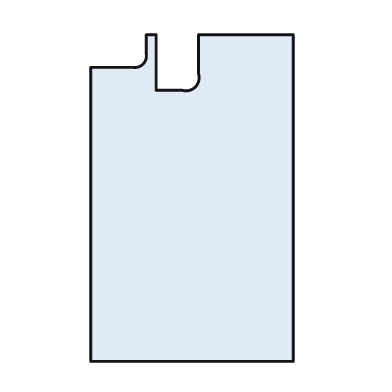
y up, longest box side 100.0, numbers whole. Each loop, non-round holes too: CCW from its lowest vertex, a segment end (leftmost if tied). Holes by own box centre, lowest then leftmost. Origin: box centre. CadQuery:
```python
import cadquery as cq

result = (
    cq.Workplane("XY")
    .moveTo(-31.0, -50.0)
    .lineTo(31.0, -50.0)
    .lineTo(31.0, 50.0)
    .lineTo(2.0, 50.0)
    .lineTo(2.0, 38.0)
    .threePointArc((1.0, 34.0), (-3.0, 33.0))
    .lineTo(-11.0, 33.0)
    .lineTo(-11.0, 50.0)
    .lineTo(-14.0, 50.0)
    .lineTo(-14.0, 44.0)
    .threePointArc((-15.0, 41.0), (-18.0, 40.0))
    .lineTo(-31.0, 40.0)
    .close()
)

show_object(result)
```